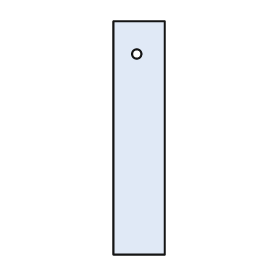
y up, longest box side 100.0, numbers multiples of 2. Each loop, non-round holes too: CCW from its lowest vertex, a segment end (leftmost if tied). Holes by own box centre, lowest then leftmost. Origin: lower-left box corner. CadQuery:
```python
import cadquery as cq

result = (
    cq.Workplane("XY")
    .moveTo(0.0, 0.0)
    .lineTo(22.0, 0.0)
    .lineTo(22.0, 100.0)
    .lineTo(0.0, 100.0)
    .close()
    .moveTo(10.0, 86.0)
    .circle(2.0)
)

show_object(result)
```